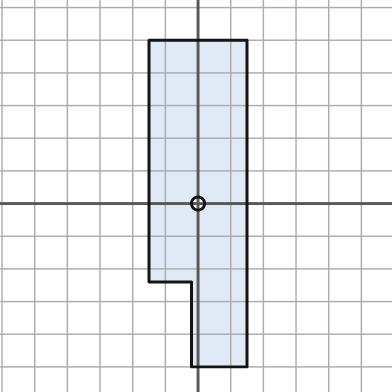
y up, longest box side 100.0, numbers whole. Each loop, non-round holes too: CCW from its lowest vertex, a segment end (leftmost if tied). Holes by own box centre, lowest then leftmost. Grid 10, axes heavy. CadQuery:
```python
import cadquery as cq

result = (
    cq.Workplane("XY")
    .moveTo(-2.0, -50.0)
    .lineTo(15.0, -50.0)
    .lineTo(15.0, 50.0)
    .lineTo(-15.0, 50.0)
    .lineTo(-15.0, -24.0)
    .lineTo(-2.0, -24.0)
    .close()
    .moveTo(0.0, 0.0)
    .circle(2.0)
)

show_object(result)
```